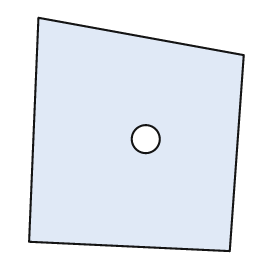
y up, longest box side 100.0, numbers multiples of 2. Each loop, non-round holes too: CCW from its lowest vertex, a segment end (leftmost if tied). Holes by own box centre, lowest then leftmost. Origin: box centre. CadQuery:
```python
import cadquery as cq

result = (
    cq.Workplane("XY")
    .moveTo(40.0, -50.0)
    .lineTo(46.0, 34.0)
    .lineTo(-42.0, 50.0)
    .lineTo(-46.0, -46.0)
    .close()
    .moveTo(4.0, -2.0)
    .circle(6.0)
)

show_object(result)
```